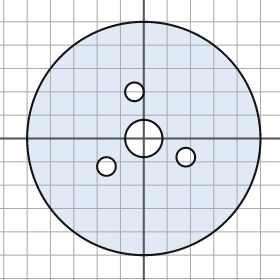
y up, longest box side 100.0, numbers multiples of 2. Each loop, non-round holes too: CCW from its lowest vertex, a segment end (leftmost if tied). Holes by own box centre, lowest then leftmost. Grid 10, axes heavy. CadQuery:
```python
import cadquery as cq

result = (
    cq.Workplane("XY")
    .moveTo(0.0, 0.0)
    .circle(50.0)
    .moveTo(-16.0, -12.0)
    .circle(4.0)
    .moveTo(18.0, -8.0)
    .circle(4.0)
    .moveTo(0.0, 0.0)
    .circle(8.0)
    .moveTo(-4.0, 20.0)
    .circle(4.0)
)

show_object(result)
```